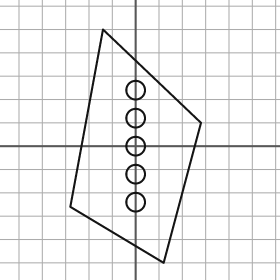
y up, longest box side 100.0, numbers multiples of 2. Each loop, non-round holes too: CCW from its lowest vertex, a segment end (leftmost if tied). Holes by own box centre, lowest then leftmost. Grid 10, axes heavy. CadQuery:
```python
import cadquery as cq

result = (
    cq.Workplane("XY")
    .moveTo(12.0, -50.0)
    .lineTo(28.0, 10.0)
    .lineTo(-14.0, 50.0)
    .lineTo(-28.0, -26.0)
    .close()
    .moveTo(0.0, -24.0)
    .circle(4.0)
    .moveTo(0.0, -12.0)
    .circle(4.0)
    .moveTo(0.0, 0.0)
    .circle(4.0)
    .moveTo(0.0, 12.0)
    .circle(4.0)
    .moveTo(0.0, 24.0)
    .circle(4.0)
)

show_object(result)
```